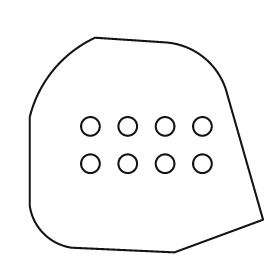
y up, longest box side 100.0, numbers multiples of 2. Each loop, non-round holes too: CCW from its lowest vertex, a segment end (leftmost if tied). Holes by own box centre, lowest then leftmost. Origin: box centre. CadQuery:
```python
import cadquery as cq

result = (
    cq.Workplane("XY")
    .moveTo(12.0, -46.0)
    .lineTo(50.0, -32.0)
    .lineTo(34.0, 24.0)
    .threePointArc((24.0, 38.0), (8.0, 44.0))
    .lineTo(-22.0, 46.0)
    .threePointArc((-40.0, 32.0), (-50.0, 12.0))
    .lineTo(-50.0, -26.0)
    .threePointArc((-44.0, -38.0), (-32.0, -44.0))
    .close()
    .moveTo(-24.0, -8.0)
    .circle(4.0)
    .moveTo(-8.0, -8.0)
    .circle(4.0)
    .moveTo(8.0, -8.0)
    .circle(4.0)
    .moveTo(24.0, -8.0)
    .circle(4.0)
    .moveTo(-24.0, 8.0)
    .circle(4.0)
    .moveTo(-8.0, 8.0)
    .circle(4.0)
    .moveTo(8.0, 8.0)
    .circle(4.0)
    .moveTo(24.0, 8.0)
    .circle(4.0)
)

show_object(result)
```